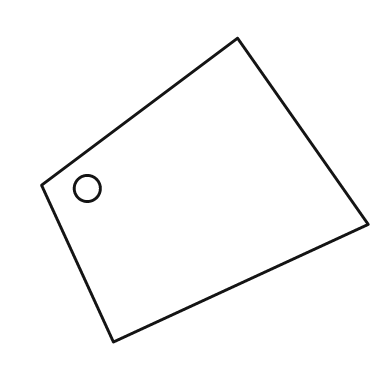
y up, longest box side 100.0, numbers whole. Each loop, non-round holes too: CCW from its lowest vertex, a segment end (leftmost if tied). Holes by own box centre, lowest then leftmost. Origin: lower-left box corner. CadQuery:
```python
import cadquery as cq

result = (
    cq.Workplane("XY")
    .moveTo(22.0, 0.0)
    .lineTo(100.0, 36.0)
    .lineTo(60.0, 93.0)
    .lineTo(0.0, 48.0)
    .close()
    .moveTo(14.0, 47.0)
    .circle(4.0)
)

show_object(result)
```